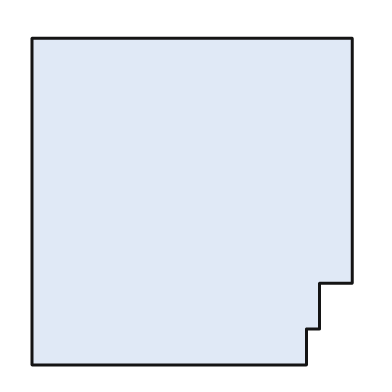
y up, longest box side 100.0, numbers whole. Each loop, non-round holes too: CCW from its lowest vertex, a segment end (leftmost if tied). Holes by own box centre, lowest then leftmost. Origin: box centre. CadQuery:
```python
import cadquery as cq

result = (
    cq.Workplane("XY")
    .moveTo(-49.0, -50.0)
    .lineTo(35.0, -50.0)
    .lineTo(35.0, -39.0)
    .lineTo(39.0, -39.0)
    .lineTo(39.0, -25.0)
    .lineTo(49.0, -25.0)
    .lineTo(49.0, 50.0)
    .lineTo(-49.0, 50.0)
    .close()
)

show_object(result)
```